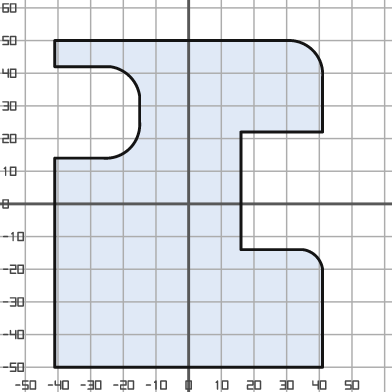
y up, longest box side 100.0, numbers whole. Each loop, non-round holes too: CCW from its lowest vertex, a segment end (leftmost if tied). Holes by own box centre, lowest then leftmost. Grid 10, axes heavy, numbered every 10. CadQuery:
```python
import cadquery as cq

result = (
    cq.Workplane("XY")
    .moveTo(-41.0, -50.0)
    .lineTo(41.0, -50.0)
    .lineTo(41.0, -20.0)
    .threePointArc((39.0, -16.0), (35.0, -14.0))
    .lineTo(16.0, -14.0)
    .lineTo(16.0, 22.0)
    .lineTo(41.0, 22.0)
    .lineTo(41.0, 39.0)
    .threePointArc((38.0, 47.0), (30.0, 50.0))
    .lineTo(-41.0, 50.0)
    .lineTo(-41.0, 42.0)
    .lineTo(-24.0, 42.0)
    .threePointArc((-18.0, 39.0), (-15.0, 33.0))
    .lineTo(-15.0, 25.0)
    .threePointArc((-18.0, 17.0), (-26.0, 14.0))
    .lineTo(-41.0, 14.0)
    .close()
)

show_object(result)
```